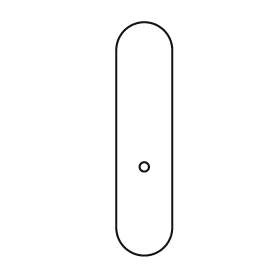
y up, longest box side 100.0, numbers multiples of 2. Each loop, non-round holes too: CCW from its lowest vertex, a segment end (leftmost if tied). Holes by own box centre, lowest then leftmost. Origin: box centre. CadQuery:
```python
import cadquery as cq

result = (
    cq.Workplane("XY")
    .moveTo(-12.0, -38.0)
    .threePointArc((0.0, -50.0), (12.0, -38.0))
    .lineTo(12.0, 38.0)
    .threePointArc((0.0, 50.0), (-12.0, 38.0))
    .close()
    .moveTo(0.0, -12.0)
    .circle(2.0)
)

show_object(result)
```